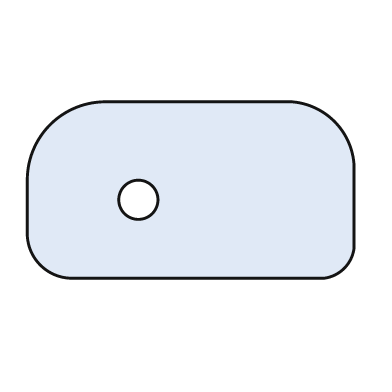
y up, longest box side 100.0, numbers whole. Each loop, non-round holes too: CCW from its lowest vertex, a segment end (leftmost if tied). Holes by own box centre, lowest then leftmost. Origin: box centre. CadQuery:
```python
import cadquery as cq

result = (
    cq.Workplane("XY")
    .moveTo(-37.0, -27.0)
    .lineTo(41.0, -27.0)
    .threePointArc((47.0, -24.0), (50.0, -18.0))
    .lineTo(50.0, 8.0)
    .threePointArc((44.0, 21.0), (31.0, 27.0))
    .lineTo(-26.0, 27.0)
    .threePointArc((-43.0, 20.0), (-50.0, 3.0))
    .lineTo(-50.0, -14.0)
    .threePointArc((-46.0, -23.0), (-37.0, -27.0))
    .close()
    .moveTo(-16.0, -3.0)
    .circle(6.0)
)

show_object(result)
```